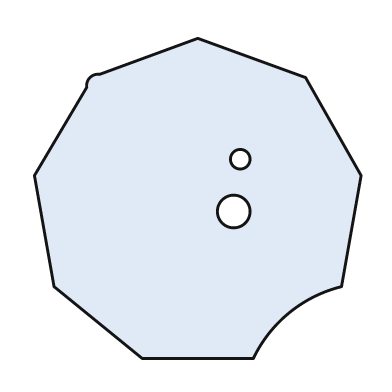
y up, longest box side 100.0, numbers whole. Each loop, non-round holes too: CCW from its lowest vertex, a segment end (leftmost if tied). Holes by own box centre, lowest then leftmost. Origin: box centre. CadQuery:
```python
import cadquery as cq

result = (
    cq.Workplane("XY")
    .moveTo(-17.0, -49.0)
    .lineTo(17.0, -49.0)
    .threePointArc((28.0, -35.0), (44.0, -27.0))
    .lineTo(50.0, 7.0)
    .lineTo(33.0, 37.0)
    .lineTo(0.0, 49.0)
    .lineTo(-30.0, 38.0)
    .threePointArc((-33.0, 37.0), (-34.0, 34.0))
    .lineTo(-50.0, 7.0)
    .lineTo(-44.0, -27.0)
    .close()
    .moveTo(11.0, -4.0)
    .circle(5.0)
    .moveTo(13.0, 12.0)
    .circle(3.0)
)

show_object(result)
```